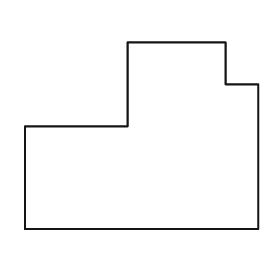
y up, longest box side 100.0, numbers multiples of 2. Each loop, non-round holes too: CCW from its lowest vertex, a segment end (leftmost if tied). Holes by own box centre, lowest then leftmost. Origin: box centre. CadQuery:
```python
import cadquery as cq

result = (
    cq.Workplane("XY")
    .moveTo(-50.0, -40.0)
    .lineTo(50.0, -40.0)
    .lineTo(50.0, 22.0)
    .lineTo(36.0, 22.0)
    .lineTo(36.0, 40.0)
    .lineTo(-6.0, 40.0)
    .lineTo(-6.0, 4.0)
    .lineTo(-50.0, 4.0)
    .close()
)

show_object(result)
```